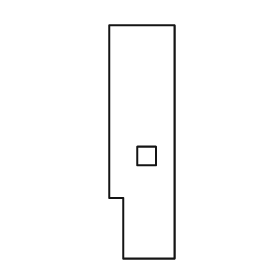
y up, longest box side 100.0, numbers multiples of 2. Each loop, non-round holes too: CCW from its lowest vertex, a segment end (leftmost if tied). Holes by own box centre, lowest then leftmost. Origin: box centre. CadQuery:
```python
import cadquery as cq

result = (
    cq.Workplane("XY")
    .moveTo(-8.0, -50.0)
    .lineTo(14.0, -50.0)
    .lineTo(14.0, 50.0)
    .lineTo(-14.0, 50.0)
    .lineTo(-14.0, -24.0)
    .lineTo(-8.0, -24.0)
    .close()
    .moveTo(-2.0, -10.0)
    .lineTo(6.0, -10.0)
    .lineTo(6.0, -2.0)
    .lineTo(-2.0, -2.0)
    .close()
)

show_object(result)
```